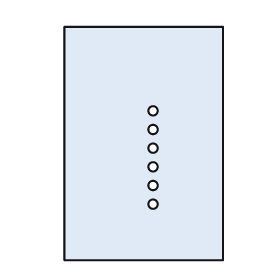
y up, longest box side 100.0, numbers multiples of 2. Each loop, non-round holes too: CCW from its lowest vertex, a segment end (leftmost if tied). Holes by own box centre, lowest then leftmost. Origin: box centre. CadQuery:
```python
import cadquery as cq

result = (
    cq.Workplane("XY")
    .moveTo(-34.0, -50.0)
    .lineTo(34.0, -50.0)
    .lineTo(34.0, 50.0)
    .lineTo(-34.0, 50.0)
    .close()
    .moveTo(4.0, -26.0)
    .circle(2.0)
    .moveTo(4.0, -18.0)
    .circle(2.0)
    .moveTo(4.0, -10.0)
    .circle(2.0)
    .moveTo(4.0, -2.0)
    .circle(2.0)
    .moveTo(4.0, 6.0)
    .circle(2.0)
    .moveTo(4.0, 14.0)
    .circle(2.0)
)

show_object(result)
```